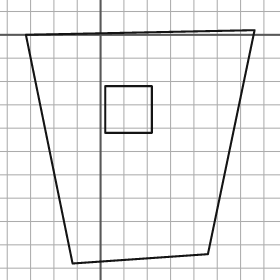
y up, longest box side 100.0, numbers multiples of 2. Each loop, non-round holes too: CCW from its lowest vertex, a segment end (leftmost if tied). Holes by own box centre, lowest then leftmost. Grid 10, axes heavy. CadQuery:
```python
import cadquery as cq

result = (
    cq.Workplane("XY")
    .moveTo(-12.0, -98.0)
    .lineTo(46.0, -94.0)
    .lineTo(66.0, 2.0)
    .lineTo(-32.0, 0.0)
    .close()
    .moveTo(2.0, -42.0)
    .lineTo(22.0, -42.0)
    .lineTo(22.0, -22.0)
    .lineTo(2.0, -22.0)
    .close()
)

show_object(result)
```